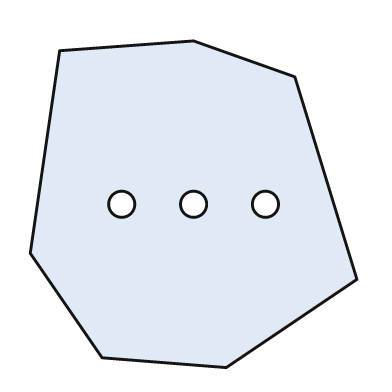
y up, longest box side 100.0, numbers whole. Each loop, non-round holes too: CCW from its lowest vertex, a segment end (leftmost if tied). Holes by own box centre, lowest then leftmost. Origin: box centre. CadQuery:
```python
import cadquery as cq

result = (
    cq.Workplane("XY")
    .moveTo(10.0, -50.0)
    .lineTo(50.0, -23.0)
    .lineTo(31.0, 39.0)
    .lineTo(0.0, 50.0)
    .lineTo(-41.0, 47.0)
    .lineTo(-50.0, -15.0)
    .lineTo(-28.0, -47.0)
    .close()
    .moveTo(-22.0, 0.0)
    .circle(4.0)
    .moveTo(0.0, 0.0)
    .circle(4.0)
    .moveTo(22.0, 0.0)
    .circle(4.0)
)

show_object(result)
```